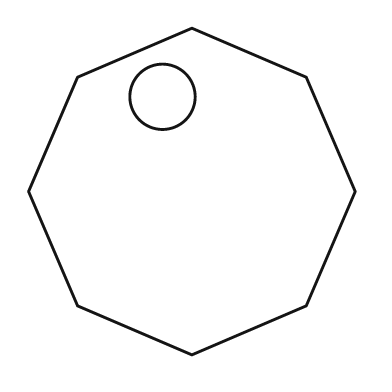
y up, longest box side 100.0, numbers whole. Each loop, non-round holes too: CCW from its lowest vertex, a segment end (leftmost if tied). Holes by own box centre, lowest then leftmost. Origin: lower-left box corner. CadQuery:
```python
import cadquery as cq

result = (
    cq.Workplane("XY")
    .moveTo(50.0, 0.0)
    .lineTo(85.0, 15.0)
    .lineTo(100.0, 50.0)
    .lineTo(85.0, 85.0)
    .lineTo(50.0, 100.0)
    .lineTo(15.0, 85.0)
    .lineTo(0.0, 50.0)
    .lineTo(15.0, 15.0)
    .close()
    .moveTo(41.0, 79.0)
    .circle(10.0)
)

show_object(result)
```